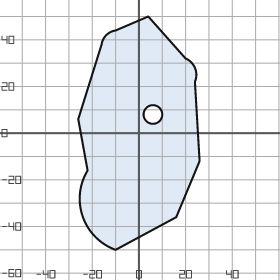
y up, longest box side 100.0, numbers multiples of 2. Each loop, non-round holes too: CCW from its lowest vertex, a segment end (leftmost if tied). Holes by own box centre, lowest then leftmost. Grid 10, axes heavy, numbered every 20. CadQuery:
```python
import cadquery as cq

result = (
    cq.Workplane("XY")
    .moveTo(-10.0, -50.0)
    .lineTo(16.0, -36.0)
    .lineTo(26.0, -12.0)
    .lineTo(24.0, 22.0)
    .threePointArc((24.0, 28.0), (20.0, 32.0))
    .lineTo(4.0, 50.0)
    .lineTo(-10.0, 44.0)
    .threePointArc((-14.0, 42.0), (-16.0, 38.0))
    .lineTo(-26.0, 6.0)
    .lineTo(-22.0, -16.0)
    .threePointArc((-24.0, -36.0), (-10.0, -50.0))
    .close()
    .moveTo(6.0, 8.0)
    .circle(4.0)
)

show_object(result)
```